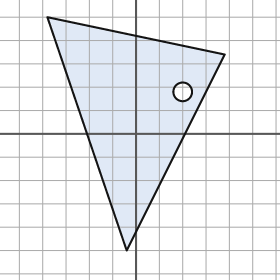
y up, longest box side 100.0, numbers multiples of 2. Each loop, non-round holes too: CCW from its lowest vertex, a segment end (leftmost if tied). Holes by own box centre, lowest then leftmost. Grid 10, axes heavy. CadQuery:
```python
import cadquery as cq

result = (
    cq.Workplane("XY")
    .moveTo(-4.0, -50.0)
    .lineTo(38.0, 34.0)
    .lineTo(-38.0, 50.0)
    .close()
    .moveTo(20.0, 18.0)
    .circle(4.0)
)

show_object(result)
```